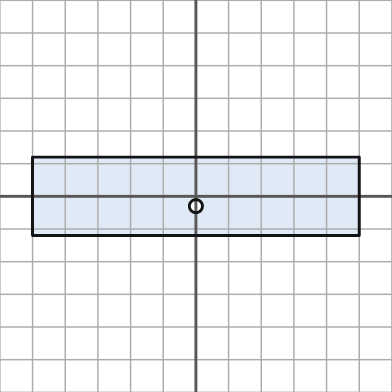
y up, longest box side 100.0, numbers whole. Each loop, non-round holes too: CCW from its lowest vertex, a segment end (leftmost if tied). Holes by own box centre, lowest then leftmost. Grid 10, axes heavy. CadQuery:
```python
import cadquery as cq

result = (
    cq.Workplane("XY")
    .moveTo(-50.0, -12.0)
    .lineTo(50.0, -12.0)
    .lineTo(50.0, 12.0)
    .lineTo(-50.0, 12.0)
    .close()
    .moveTo(0.0, -3.0)
    .circle(2.0)
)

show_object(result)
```